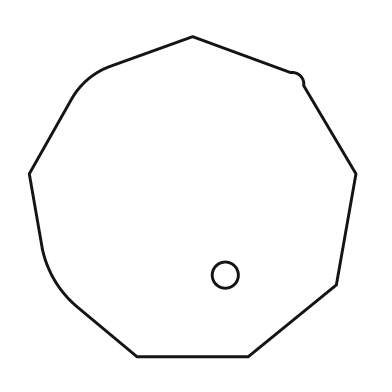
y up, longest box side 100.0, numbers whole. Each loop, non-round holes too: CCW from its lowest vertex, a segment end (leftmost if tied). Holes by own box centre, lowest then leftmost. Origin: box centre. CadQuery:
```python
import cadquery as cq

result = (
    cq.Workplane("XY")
    .moveTo(-17.0, -49.0)
    .lineTo(17.0, -49.0)
    .lineTo(44.0, -27.0)
    .lineTo(50.0, 7.0)
    .lineTo(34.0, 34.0)
    .threePointArc((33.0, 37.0), (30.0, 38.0))
    .lineTo(0.0, 49.0)
    .lineTo(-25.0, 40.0)
    .threePointArc((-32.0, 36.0), (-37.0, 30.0))
    .lineTo(-50.0, 7.0)
    .lineTo(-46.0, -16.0)
    .threePointArc((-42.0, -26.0), (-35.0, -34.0))
    .close()
    .moveTo(10.0, -24.0)
    .circle(4.0)
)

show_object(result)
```